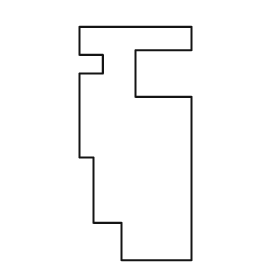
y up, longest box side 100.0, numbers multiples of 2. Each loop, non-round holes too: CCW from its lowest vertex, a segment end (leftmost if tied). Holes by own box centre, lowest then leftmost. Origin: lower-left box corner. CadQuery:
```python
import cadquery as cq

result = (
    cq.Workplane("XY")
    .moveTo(18.0, 0.0)
    .lineTo(48.0, 0.0)
    .lineTo(48.0, 70.0)
    .lineTo(24.0, 70.0)
    .lineTo(24.0, 90.0)
    .lineTo(48.0, 90.0)
    .lineTo(48.0, 100.0)
    .lineTo(0.0, 100.0)
    .lineTo(0.0, 88.0)
    .lineTo(10.0, 88.0)
    .lineTo(10.0, 80.0)
    .lineTo(0.0, 80.0)
    .lineTo(0.0, 44.0)
    .lineTo(6.0, 44.0)
    .lineTo(6.0, 16.0)
    .lineTo(18.0, 16.0)
    .close()
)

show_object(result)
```